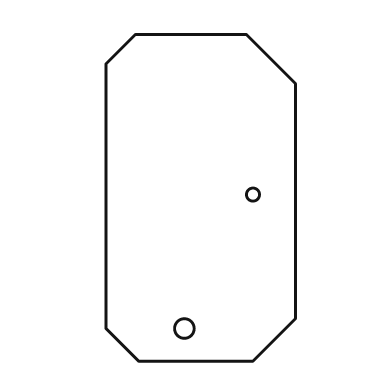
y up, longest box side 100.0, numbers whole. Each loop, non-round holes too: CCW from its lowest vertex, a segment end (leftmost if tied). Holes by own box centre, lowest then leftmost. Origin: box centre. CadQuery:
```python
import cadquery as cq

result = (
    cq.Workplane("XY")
    .moveTo(-19.0, -50.0)
    .lineTo(16.0, -50.0)
    .lineTo(29.0, -37.0)
    .lineTo(29.0, 35.0)
    .lineTo(14.0, 50.0)
    .lineTo(-20.0, 50.0)
    .lineTo(-29.0, 41.0)
    .lineTo(-29.0, -40.0)
    .close()
    .moveTo(-5.0, -40.0)
    .circle(3.0)
    .moveTo(16.0, 1.0)
    .circle(2.0)
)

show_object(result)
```